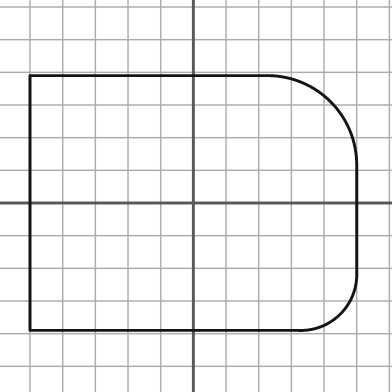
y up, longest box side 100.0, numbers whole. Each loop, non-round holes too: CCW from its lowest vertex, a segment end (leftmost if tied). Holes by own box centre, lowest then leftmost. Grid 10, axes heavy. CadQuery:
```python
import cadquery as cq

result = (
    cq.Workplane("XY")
    .moveTo(-50.0, -39.0)
    .lineTo(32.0, -39.0)
    .threePointArc((45.0, -34.0), (50.0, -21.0))
    .lineTo(50.0, 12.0)
    .threePointArc((42.0, 31.0), (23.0, 39.0))
    .lineTo(-50.0, 39.0)
    .close()
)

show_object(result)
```